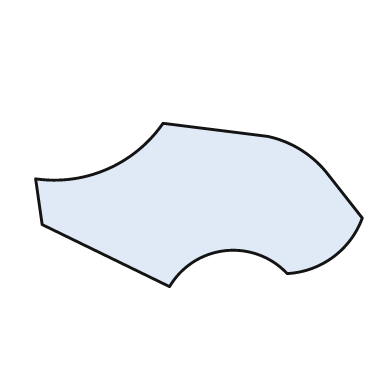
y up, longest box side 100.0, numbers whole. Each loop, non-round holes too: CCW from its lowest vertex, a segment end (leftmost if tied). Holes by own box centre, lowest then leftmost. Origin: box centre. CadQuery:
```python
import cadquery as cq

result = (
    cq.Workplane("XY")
    .moveTo(-9.0, -25.0)
    .threePointArc((8.0, -14.0), (27.0, -21.0))
    .threePointArc((41.0, -16.0), (50.0, -4.0))
    .lineTo(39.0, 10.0)
    .threePointArc((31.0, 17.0), (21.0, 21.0))
    .lineTo(-11.0, 25.0)
    .threePointArc((-28.0, 11.0), (-50.0, 8.0))
    .lineTo(-48.0, -6.0)
    .close()
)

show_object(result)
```